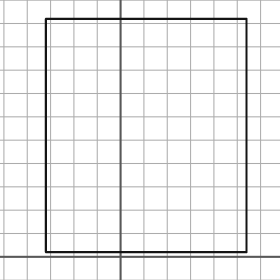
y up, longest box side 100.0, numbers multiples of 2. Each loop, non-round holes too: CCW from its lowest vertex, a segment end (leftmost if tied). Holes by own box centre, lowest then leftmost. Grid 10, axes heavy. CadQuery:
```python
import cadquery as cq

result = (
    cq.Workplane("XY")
    .moveTo(-32.0, 2.0)
    .lineTo(54.0, 2.0)
    .lineTo(54.0, 102.0)
    .lineTo(-32.0, 102.0)
    .close()
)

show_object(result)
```